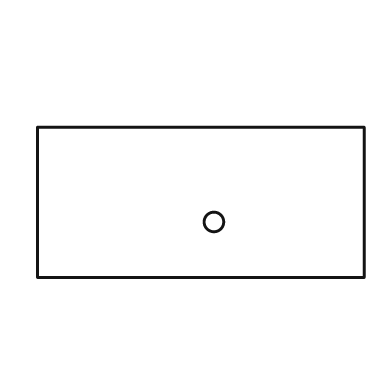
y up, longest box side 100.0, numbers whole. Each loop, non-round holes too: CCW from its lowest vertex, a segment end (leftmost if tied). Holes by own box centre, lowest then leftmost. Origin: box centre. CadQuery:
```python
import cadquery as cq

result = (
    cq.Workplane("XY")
    .moveTo(-50.0, -23.0)
    .lineTo(50.0, -23.0)
    .lineTo(50.0, 23.0)
    .lineTo(-50.0, 23.0)
    .close()
    .moveTo(4.0, -6.0)
    .circle(3.0)
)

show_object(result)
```